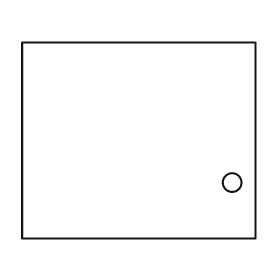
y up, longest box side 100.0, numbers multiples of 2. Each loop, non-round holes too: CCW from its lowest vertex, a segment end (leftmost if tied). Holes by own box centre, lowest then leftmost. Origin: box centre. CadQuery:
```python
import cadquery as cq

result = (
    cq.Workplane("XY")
    .moveTo(-50.0, -42.0)
    .lineTo(50.0, -42.0)
    .lineTo(50.0, 42.0)
    .lineTo(-50.0, 42.0)
    .close()
    .moveTo(40.0, -18.0)
    .circle(4.0)
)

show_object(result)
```